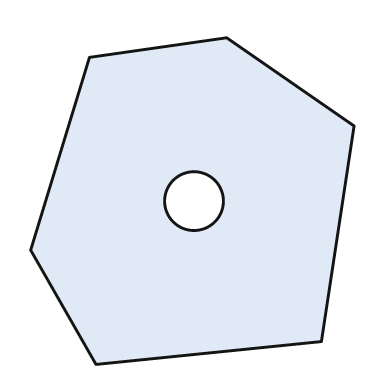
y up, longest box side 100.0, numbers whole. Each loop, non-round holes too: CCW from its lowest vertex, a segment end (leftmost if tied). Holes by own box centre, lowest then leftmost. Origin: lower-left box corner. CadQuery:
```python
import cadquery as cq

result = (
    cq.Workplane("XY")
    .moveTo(20.0, 0.0)
    .lineTo(89.0, 7.0)
    .lineTo(99.0, 73.0)
    .lineTo(60.0, 100.0)
    .lineTo(18.0, 94.0)
    .lineTo(0.0, 35.0)
    .close()
    .moveTo(50.0, 50.0)
    .circle(9.0)
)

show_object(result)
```